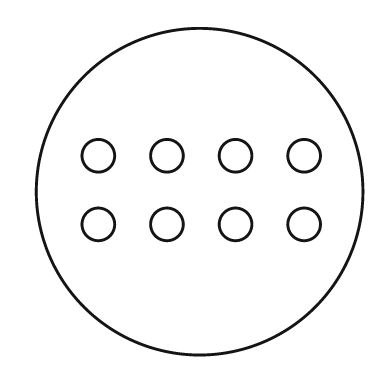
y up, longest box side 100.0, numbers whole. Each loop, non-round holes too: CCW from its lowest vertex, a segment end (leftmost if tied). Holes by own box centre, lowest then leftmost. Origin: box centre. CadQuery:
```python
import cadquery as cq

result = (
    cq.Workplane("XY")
    .moveTo(0.0, 0.0)
    .circle(50.0)
    .moveTo(-31.0, -10.0)
    .circle(5.0)
    .moveTo(-10.0, -10.0)
    .circle(5.0)
    .moveTo(11.0, -10.0)
    .circle(5.0)
    .moveTo(32.0, -10.0)
    .circle(5.0)
    .moveTo(-31.0, 11.0)
    .circle(5.0)
    .moveTo(-10.0, 11.0)
    .circle(5.0)
    .moveTo(11.0, 11.0)
    .circle(5.0)
    .moveTo(32.0, 11.0)
    .circle(5.0)
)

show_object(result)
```